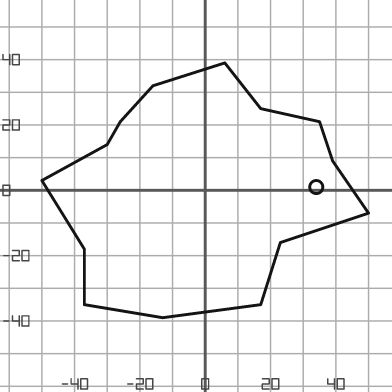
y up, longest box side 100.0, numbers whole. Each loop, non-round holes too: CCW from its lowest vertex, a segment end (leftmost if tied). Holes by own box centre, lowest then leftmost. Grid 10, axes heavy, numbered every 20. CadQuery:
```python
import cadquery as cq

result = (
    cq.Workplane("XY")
    .moveTo(-13.0, -39.0)
    .lineTo(17.0, -35.0)
    .lineTo(23.0, -16.0)
    .lineTo(50.0, -7.0)
    .lineTo(39.0, 9.0)
    .lineTo(35.0, 21.0)
    .lineTo(17.0, 25.0)
    .lineTo(6.0, 39.0)
    .lineTo(-16.0, 32.0)
    .lineTo(-26.0, 21.0)
    .lineTo(-30.0, 14.0)
    .lineTo(-50.0, 3.0)
    .lineTo(-37.0, -18.0)
    .lineTo(-37.0, -35.0)
    .close()
    .moveTo(34.0, 1.0)
    .circle(2.0)
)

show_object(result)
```